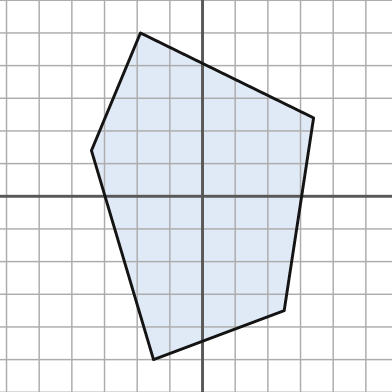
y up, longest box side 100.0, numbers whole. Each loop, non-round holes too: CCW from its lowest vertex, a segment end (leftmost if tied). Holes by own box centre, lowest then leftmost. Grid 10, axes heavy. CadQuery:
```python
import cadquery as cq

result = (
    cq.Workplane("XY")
    .moveTo(-15.0, -50.0)
    .lineTo(25.0, -35.0)
    .lineTo(34.0, 24.0)
    .lineTo(-19.0, 50.0)
    .lineTo(-34.0, 14.0)
    .close()
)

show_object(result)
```